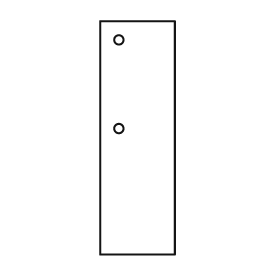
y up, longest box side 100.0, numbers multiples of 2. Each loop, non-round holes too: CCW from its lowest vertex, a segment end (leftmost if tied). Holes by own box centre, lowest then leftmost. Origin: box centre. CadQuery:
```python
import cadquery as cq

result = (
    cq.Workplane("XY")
    .moveTo(-16.0, -50.0)
    .lineTo(16.0, -50.0)
    .lineTo(16.0, 50.0)
    .lineTo(-16.0, 50.0)
    .close()
    .moveTo(-8.0, 4.0)
    .circle(2.0)
    .moveTo(-8.0, 42.0)
    .circle(2.0)
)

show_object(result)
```